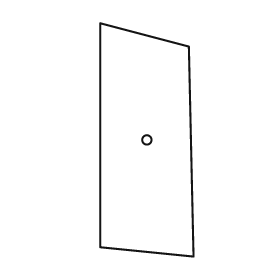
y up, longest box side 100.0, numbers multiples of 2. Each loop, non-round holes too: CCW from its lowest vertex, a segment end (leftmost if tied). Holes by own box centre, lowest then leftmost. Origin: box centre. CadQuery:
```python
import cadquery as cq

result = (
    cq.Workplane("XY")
    .moveTo(20.0, -50.0)
    .lineTo(18.0, 40.0)
    .lineTo(-20.0, 50.0)
    .lineTo(-20.0, -46.0)
    .close()
    .moveTo(0.0, 0.0)
    .circle(2.0)
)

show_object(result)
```